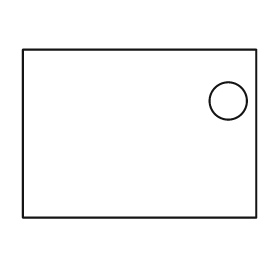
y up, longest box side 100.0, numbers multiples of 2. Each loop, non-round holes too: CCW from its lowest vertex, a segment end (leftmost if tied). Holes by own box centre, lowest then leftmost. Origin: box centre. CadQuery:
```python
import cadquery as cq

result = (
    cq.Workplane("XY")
    .moveTo(-50.0, -36.0)
    .lineTo(50.0, -36.0)
    .lineTo(50.0, 36.0)
    .lineTo(-50.0, 36.0)
    .close()
    .moveTo(38.0, 14.0)
    .circle(8.0)
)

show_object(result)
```